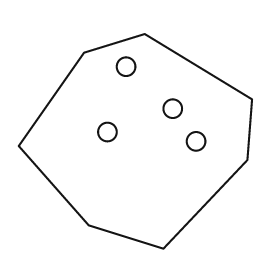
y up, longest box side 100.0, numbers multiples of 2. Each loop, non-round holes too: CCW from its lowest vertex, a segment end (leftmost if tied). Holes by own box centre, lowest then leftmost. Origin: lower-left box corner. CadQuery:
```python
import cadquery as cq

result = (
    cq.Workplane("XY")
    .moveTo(62.0, 0.0)
    .lineTo(98.0, 38.0)
    .lineTo(100.0, 64.0)
    .lineTo(54.0, 92.0)
    .lineTo(28.0, 84.0)
    .lineTo(0.0, 44.0)
    .lineTo(30.0, 10.0)
    .close()
    .moveTo(76.0, 46.0)
    .circle(4.0)
    .moveTo(38.0, 50.0)
    .circle(4.0)
    .moveTo(66.0, 60.0)
    .circle(4.0)
    .moveTo(46.0, 78.0)
    .circle(4.0)
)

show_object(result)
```